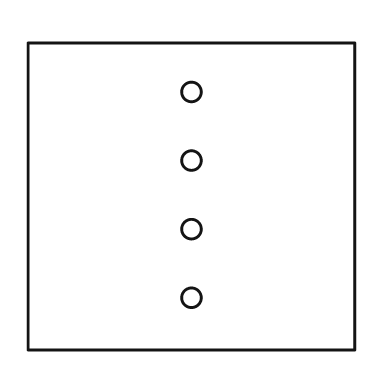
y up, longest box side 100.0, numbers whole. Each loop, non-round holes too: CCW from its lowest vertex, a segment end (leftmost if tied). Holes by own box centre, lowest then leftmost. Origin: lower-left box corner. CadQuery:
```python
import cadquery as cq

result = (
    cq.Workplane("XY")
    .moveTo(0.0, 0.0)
    .lineTo(100.0, 0.0)
    .lineTo(100.0, 94.0)
    .lineTo(0.0, 94.0)
    .close()
    .moveTo(50.0, 16.0)
    .circle(3.0)
    .moveTo(50.0, 37.0)
    .circle(3.0)
    .moveTo(50.0, 58.0)
    .circle(3.0)
    .moveTo(50.0, 79.0)
    .circle(3.0)
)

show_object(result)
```